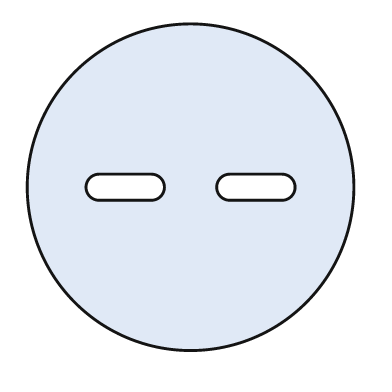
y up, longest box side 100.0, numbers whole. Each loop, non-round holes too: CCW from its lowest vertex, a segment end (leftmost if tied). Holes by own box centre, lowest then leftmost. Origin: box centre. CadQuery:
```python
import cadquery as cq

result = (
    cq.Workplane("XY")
    .moveTo(0.0, 0.0)
    .circle(50.0)
    .moveTo(-28.0, -4.0)
    .lineTo(-12.0, -4.0)
    .threePointArc((-8.0, 0.0), (-12.0, 4.0))
    .lineTo(-28.0, 4.0)
    .threePointArc((-32.0, 0.0), (-28.0, -4.0))
    .close()
    .moveTo(12.0, -4.0)
    .lineTo(28.0, -4.0)
    .threePointArc((32.0, 0.0), (28.0, 4.0))
    .lineTo(12.0, 4.0)
    .threePointArc((8.0, 0.0), (12.0, -4.0))
    .close()
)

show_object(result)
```